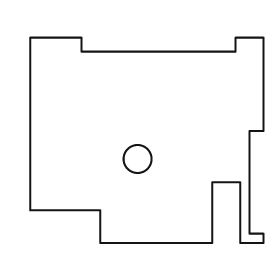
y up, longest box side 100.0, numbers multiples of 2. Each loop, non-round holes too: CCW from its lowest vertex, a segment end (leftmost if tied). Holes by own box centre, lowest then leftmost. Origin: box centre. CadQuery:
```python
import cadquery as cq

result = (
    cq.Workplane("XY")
    .moveTo(-20.0, -44.0)
    .lineTo(28.0, -44.0)
    .lineTo(28.0, -18.0)
    .lineTo(40.0, -18.0)
    .lineTo(40.0, -44.0)
    .lineTo(50.0, -44.0)
    .lineTo(50.0, -40.0)
    .lineTo(44.0, -40.0)
    .lineTo(44.0, 4.0)
    .lineTo(50.0, 4.0)
    .lineTo(50.0, 44.0)
    .lineTo(38.0, 44.0)
    .lineTo(38.0, 38.0)
    .lineTo(-28.0, 38.0)
    .lineTo(-28.0, 44.0)
    .lineTo(-50.0, 44.0)
    .lineTo(-50.0, -30.0)
    .lineTo(-20.0, -30.0)
    .close()
    .moveTo(-4.0, -8.0)
    .circle(6.0)
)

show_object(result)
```